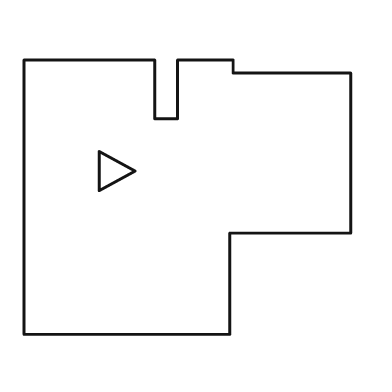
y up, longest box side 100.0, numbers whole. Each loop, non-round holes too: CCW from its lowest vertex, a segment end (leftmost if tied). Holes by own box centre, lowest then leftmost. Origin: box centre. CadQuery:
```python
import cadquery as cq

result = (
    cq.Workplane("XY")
    .moveTo(-50.0, -42.0)
    .lineTo(13.0, -42.0)
    .lineTo(13.0, -11.0)
    .lineTo(50.0, -11.0)
    .lineTo(50.0, 38.0)
    .lineTo(14.0, 38.0)
    .lineTo(14.0, 42.0)
    .lineTo(-3.0, 42.0)
    .lineTo(-3.0, 24.0)
    .lineTo(-10.0, 24.0)
    .lineTo(-10.0, 42.0)
    .lineTo(-50.0, 42.0)
    .close()
    .moveTo(-27.0, 2.0)
    .lineTo(-16.0, 8.0)
    .lineTo(-27.0, 14.0)
    .close()
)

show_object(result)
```